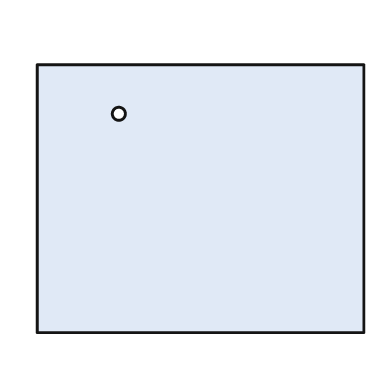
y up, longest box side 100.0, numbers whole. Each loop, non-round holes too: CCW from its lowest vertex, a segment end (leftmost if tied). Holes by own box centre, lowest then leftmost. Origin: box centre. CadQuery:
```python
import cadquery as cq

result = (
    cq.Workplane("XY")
    .moveTo(-50.0, -41.0)
    .lineTo(50.0, -41.0)
    .lineTo(50.0, 41.0)
    .lineTo(-50.0, 41.0)
    .close()
    .moveTo(-25.0, 26.0)
    .circle(2.0)
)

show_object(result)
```